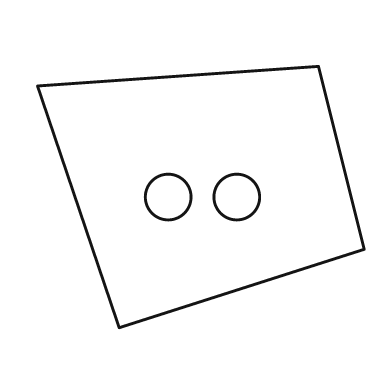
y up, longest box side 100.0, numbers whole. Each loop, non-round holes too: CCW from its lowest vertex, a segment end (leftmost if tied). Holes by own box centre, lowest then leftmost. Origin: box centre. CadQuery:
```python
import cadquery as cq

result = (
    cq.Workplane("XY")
    .moveTo(-25.0, -40.0)
    .lineTo(50.0, -16.0)
    .lineTo(36.0, 40.0)
    .lineTo(-50.0, 34.0)
    .close()
    .moveTo(-10.0, 0.0)
    .circle(7.0)
    .moveTo(11.0, 0.0)
    .circle(7.0)
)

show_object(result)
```